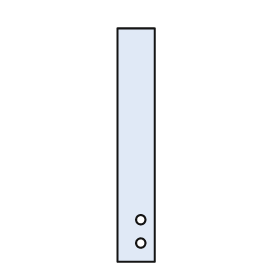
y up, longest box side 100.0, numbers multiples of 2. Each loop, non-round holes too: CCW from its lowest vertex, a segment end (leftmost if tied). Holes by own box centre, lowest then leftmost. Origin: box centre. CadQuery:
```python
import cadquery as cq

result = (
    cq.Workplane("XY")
    .moveTo(-8.0, -50.0)
    .lineTo(8.0, -50.0)
    .lineTo(8.0, 50.0)
    .lineTo(-8.0, 50.0)
    .close()
    .moveTo(2.0, -42.0)
    .circle(2.0)
    .moveTo(2.0, -32.0)
    .circle(2.0)
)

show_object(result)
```